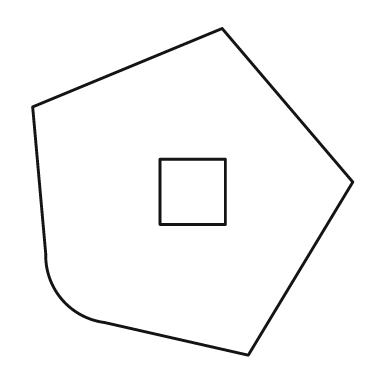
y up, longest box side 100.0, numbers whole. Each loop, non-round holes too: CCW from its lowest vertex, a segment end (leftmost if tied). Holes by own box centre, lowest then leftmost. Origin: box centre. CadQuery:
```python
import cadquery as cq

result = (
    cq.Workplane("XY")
    .moveTo(17.0, -50.0)
    .lineTo(49.0, 3.0)
    .lineTo(9.0, 50.0)
    .lineTo(-49.0, 26.0)
    .lineTo(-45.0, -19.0)
    .threePointArc((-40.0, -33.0), (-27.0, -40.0))
    .close()
    .moveTo(-10.0, -10.0)
    .lineTo(10.0, -10.0)
    .lineTo(10.0, 10.0)
    .lineTo(-10.0, 10.0)
    .close()
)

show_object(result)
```